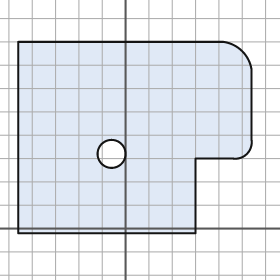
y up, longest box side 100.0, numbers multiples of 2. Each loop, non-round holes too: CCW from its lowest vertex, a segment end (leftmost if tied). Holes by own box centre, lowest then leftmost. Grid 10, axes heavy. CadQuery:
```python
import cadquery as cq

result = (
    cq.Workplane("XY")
    .moveTo(-46.0, -2.0)
    .lineTo(30.0, -2.0)
    .lineTo(30.0, 30.0)
    .lineTo(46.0, 30.0)
    .threePointArc((52.0, 32.0), (54.0, 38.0))
    .lineTo(54.0, 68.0)
    .threePointArc((50.0, 76.0), (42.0, 80.0))
    .lineTo(-46.0, 80.0)
    .close()
    .moveTo(-6.0, 32.0)
    .circle(6.0)
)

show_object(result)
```